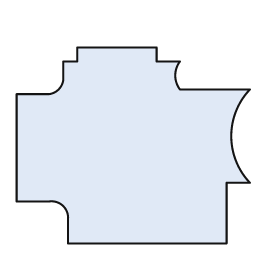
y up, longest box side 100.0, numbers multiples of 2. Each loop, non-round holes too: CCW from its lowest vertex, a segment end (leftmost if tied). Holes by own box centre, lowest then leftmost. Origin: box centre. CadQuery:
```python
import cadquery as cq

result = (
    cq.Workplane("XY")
    .moveTo(-28.0, -42.0)
    .lineTo(40.0, -42.0)
    .lineTo(40.0, -16.0)
    .lineTo(50.0, -16.0)
    .threePointArc((42.0, 4.0), (50.0, 24.0))
    .lineTo(20.0, 24.0)
    .threePointArc((18.0, 30.0), (20.0, 36.0))
    .lineTo(10.0, 36.0)
    .lineTo(10.0, 42.0)
    .lineTo(-24.0, 42.0)
    .lineTo(-24.0, 36.0)
    .lineTo(-30.0, 36.0)
    .lineTo(-30.0, 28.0)
    .threePointArc((-32.0, 24.0), (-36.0, 22.0))
    .lineTo(-50.0, 22.0)
    .lineTo(-50.0, -24.0)
    .lineTo(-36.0, -24.0)
    .threePointArc((-30.0, -26.0), (-28.0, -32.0))
    .close()
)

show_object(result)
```